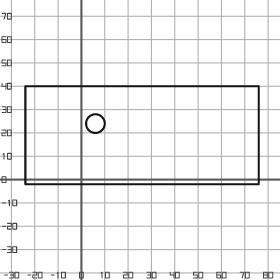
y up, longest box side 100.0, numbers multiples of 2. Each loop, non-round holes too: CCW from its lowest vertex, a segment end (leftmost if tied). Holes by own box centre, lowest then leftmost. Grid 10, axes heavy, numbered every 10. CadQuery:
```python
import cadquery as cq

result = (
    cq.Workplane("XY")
    .moveTo(-24.0, -2.0)
    .lineTo(76.0, -2.0)
    .lineTo(76.0, 40.0)
    .lineTo(-24.0, 40.0)
    .close()
    .moveTo(6.0, 24.0)
    .circle(4.0)
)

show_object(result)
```